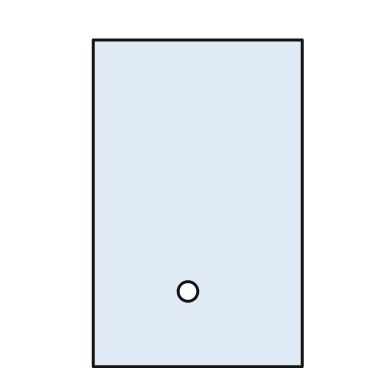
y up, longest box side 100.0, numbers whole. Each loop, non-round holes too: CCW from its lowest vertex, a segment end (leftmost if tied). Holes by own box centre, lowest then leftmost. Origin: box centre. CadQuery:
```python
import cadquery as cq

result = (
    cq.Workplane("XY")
    .moveTo(-32.0, -50.0)
    .lineTo(32.0, -50.0)
    .lineTo(32.0, 50.0)
    .lineTo(-32.0, 50.0)
    .close()
    .moveTo(-3.0, -27.0)
    .circle(3.0)
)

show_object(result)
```